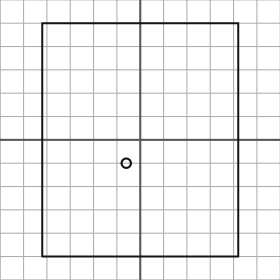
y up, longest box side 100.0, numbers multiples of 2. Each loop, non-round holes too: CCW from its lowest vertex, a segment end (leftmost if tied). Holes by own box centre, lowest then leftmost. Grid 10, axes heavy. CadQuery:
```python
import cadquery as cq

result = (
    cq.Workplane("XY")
    .moveTo(-42.0, -50.0)
    .lineTo(42.0, -50.0)
    .lineTo(42.0, 50.0)
    .lineTo(-42.0, 50.0)
    .close()
    .moveTo(-6.0, -10.0)
    .circle(2.0)
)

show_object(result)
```